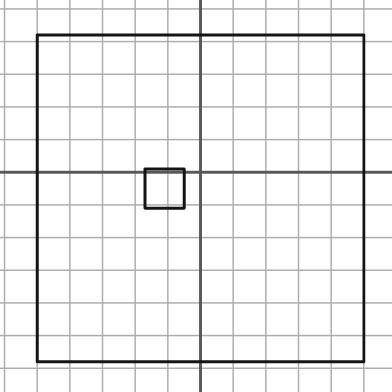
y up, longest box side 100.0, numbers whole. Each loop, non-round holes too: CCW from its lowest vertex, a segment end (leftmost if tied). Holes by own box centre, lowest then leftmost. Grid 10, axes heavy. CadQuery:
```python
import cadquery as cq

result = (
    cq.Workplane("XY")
    .moveTo(-50.0, -58.0)
    .lineTo(50.0, -58.0)
    .lineTo(50.0, 42.0)
    .lineTo(-50.0, 42.0)
    .close()
    .moveTo(-17.0, -11.0)
    .lineTo(-5.0, -11.0)
    .lineTo(-5.0, 1.0)
    .lineTo(-17.0, 1.0)
    .close()
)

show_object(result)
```